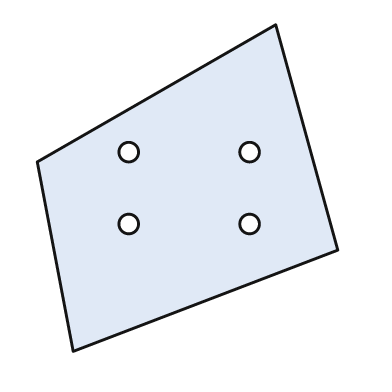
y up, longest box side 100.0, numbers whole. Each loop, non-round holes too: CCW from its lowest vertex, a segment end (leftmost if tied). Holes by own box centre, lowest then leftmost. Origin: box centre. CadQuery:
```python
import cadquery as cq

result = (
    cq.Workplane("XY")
    .moveTo(-35.0, -50.0)
    .lineTo(46.0, -19.0)
    .lineTo(27.0, 50.0)
    .lineTo(-46.0, 8.0)
    .close()
    .moveTo(-18.0, -11.0)
    .circle(3.0)
    .moveTo(19.0, -11.0)
    .circle(3.0)
    .moveTo(-18.0, 11.0)
    .circle(3.0)
    .moveTo(19.0, 11.0)
    .circle(3.0)
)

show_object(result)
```